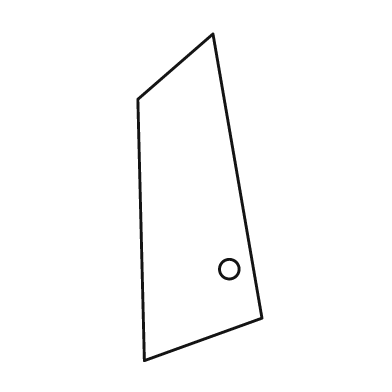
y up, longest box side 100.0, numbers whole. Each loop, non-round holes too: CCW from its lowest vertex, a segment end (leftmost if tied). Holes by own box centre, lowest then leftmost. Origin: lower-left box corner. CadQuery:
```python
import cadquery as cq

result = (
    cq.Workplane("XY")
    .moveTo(2.0, 0.0)
    .lineTo(38.0, 13.0)
    .lineTo(23.0, 100.0)
    .lineTo(0.0, 80.0)
    .close()
    .moveTo(28.0, 28.0)
    .circle(3.0)
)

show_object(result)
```